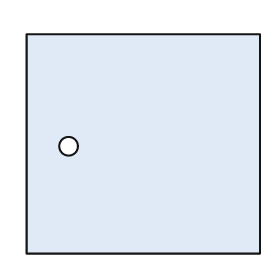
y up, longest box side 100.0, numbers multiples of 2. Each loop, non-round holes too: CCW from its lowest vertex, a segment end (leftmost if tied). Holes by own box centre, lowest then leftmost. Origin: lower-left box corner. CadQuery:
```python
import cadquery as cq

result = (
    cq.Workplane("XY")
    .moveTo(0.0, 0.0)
    .lineTo(100.0, 0.0)
    .lineTo(100.0, 94.0)
    .lineTo(0.0, 94.0)
    .close()
    .moveTo(18.0, 46.0)
    .circle(4.0)
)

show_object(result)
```